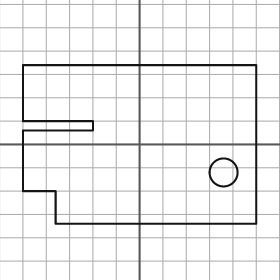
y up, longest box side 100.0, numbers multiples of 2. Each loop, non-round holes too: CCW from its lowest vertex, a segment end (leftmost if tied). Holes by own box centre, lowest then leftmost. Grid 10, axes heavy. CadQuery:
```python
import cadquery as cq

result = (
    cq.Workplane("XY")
    .moveTo(-36.0, -34.0)
    .lineTo(50.0, -34.0)
    .lineTo(50.0, 34.0)
    .lineTo(-50.0, 34.0)
    .lineTo(-50.0, 10.0)
    .lineTo(-20.0, 10.0)
    .lineTo(-20.0, 6.0)
    .lineTo(-50.0, 6.0)
    .lineTo(-50.0, -20.0)
    .lineTo(-36.0, -20.0)
    .close()
    .moveTo(36.0, -12.0)
    .circle(6.0)
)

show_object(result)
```